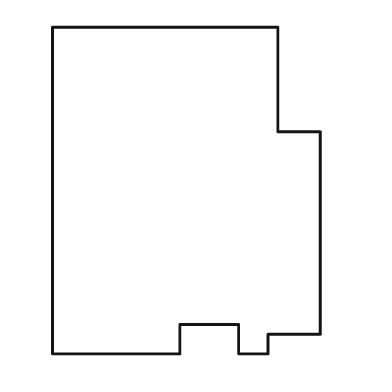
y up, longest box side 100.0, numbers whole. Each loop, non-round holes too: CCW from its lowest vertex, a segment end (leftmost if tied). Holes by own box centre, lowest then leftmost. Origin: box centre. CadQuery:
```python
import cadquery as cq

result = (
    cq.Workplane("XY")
    .moveTo(-41.0, -50.0)
    .lineTo(-2.0, -50.0)
    .lineTo(-2.0, -41.0)
    .lineTo(16.0, -41.0)
    .lineTo(16.0, -50.0)
    .lineTo(25.0, -50.0)
    .lineTo(25.0, -44.0)
    .lineTo(41.0, -44.0)
    .lineTo(41.0, 18.0)
    .lineTo(28.0, 18.0)
    .lineTo(28.0, 50.0)
    .lineTo(-41.0, 50.0)
    .close()
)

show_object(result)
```